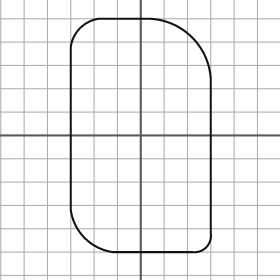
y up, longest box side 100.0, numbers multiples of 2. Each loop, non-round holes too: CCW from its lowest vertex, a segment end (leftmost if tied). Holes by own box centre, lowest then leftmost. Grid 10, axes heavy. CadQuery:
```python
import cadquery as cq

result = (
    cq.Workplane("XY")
    .moveTo(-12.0, -50.0)
    .lineTo(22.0, -50.0)
    .threePointArc((28.0, -48.0), (30.0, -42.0))
    .lineTo(30.0, 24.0)
    .threePointArc((22.0, 42.0), (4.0, 50.0))
    .lineTo(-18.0, 50.0)
    .threePointArc((-26.0, 46.0), (-30.0, 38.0))
    .lineTo(-30.0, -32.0)
    .threePointArc((-24.0, -44.0), (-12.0, -50.0))
    .close()
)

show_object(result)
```